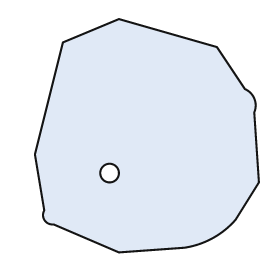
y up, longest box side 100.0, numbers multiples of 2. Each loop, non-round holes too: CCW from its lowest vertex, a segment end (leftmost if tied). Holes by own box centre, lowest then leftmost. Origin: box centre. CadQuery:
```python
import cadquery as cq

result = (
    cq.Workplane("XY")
    .moveTo(-12.0, -50.0)
    .lineTo(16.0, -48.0)
    .threePointArc((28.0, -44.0), (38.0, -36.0))
    .lineTo(48.0, -20.0)
    .lineTo(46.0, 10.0)
    .threePointArc((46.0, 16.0), (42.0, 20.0))
    .lineTo(30.0, 38.0)
    .lineTo(-12.0, 50.0)
    .lineTo(-36.0, 40.0)
    .lineTo(-48.0, -8.0)
    .lineTo(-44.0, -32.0)
    .threePointArc((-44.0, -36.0), (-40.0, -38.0))
    .close()
    .moveTo(-16.0, -16.0)
    .circle(4.0)
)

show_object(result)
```